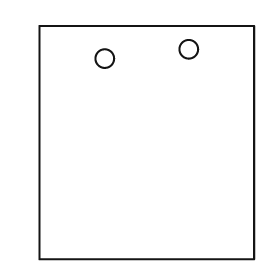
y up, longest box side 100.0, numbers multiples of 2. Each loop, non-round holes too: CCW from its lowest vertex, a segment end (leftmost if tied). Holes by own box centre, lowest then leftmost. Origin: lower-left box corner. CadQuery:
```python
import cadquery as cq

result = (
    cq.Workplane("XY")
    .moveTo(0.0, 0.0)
    .lineTo(92.0, 0.0)
    .lineTo(92.0, 100.0)
    .lineTo(0.0, 100.0)
    .close()
    .moveTo(28.0, 86.0)
    .circle(4.0)
    .moveTo(64.0, 90.0)
    .circle(4.0)
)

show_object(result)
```